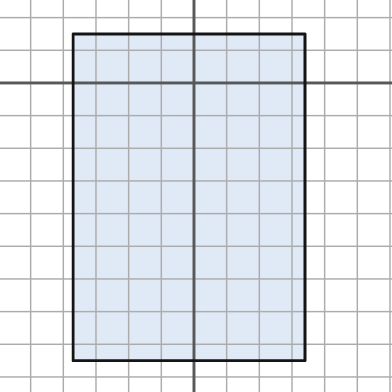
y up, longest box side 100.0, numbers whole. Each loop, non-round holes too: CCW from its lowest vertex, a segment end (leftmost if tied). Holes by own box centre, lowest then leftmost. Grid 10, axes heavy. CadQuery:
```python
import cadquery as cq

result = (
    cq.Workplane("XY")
    .moveTo(-37.0, -85.0)
    .lineTo(34.0, -85.0)
    .lineTo(34.0, 15.0)
    .lineTo(-37.0, 15.0)
    .close()
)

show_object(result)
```